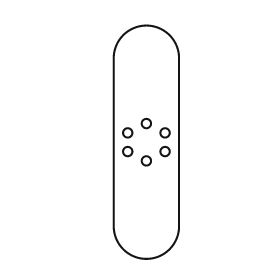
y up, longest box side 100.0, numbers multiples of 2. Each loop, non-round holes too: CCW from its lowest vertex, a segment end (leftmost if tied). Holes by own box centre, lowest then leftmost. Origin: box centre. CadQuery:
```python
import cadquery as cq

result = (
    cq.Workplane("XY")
    .moveTo(-14.0, -36.0)
    .threePointArc((0.0, -50.0), (14.0, -36.0))
    .lineTo(14.0, 36.0)
    .threePointArc((0.0, 50.0), (-14.0, 36.0))
    .close()
    .moveTo(0.0, -8.0)
    .circle(2.0)
    .moveTo(-8.0, -4.0)
    .circle(2.0)
    .moveTo(8.0, -4.0)
    .circle(2.0)
    .moveTo(-8.0, 4.0)
    .circle(2.0)
    .moveTo(8.0, 4.0)
    .circle(2.0)
    .moveTo(0.0, 8.0)
    .circle(2.0)
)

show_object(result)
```